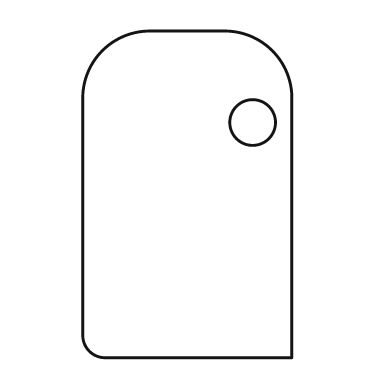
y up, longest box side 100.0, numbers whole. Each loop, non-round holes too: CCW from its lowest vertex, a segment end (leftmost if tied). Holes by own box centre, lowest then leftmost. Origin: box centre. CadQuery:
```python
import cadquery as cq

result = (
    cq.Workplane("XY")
    .moveTo(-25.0, -50.0)
    .lineTo(32.0, -50.0)
    .lineTo(32.0, 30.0)
    .threePointArc((26.0, 44.0), (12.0, 50.0))
    .lineTo(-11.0, 50.0)
    .threePointArc((-26.0, 44.0), (-32.0, 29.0))
    .lineTo(-32.0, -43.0)
    .threePointArc((-30.0, -48.0), (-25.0, -50.0))
    .close()
    .moveTo(20.0, 22.0)
    .circle(7.0)
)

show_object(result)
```